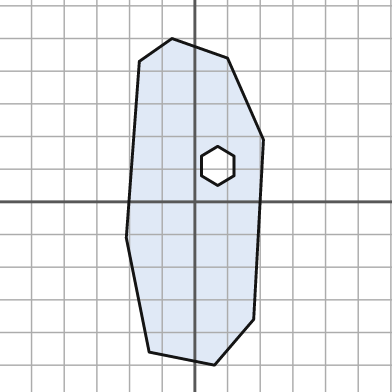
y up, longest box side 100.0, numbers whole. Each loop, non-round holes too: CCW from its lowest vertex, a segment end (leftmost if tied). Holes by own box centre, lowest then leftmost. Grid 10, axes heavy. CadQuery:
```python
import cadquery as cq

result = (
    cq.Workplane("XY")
    .moveTo(6.0, -50.0)
    .lineTo(18.0, -36.0)
    .lineTo(21.0, 19.0)
    .lineTo(10.0, 44.0)
    .lineTo(-7.0, 50.0)
    .lineTo(-17.0, 43.0)
    .lineTo(-21.0, -11.0)
    .lineTo(-14.0, -46.0)
    .close()
    .moveTo(7.0, 5.0)
    .lineTo(12.0, 8.0)
    .lineTo(12.0, 14.0)
    .lineTo(7.0, 17.0)
    .lineTo(2.0, 14.0)
    .lineTo(2.0, 8.0)
    .close()
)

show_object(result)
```